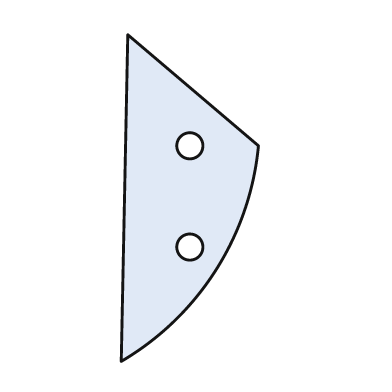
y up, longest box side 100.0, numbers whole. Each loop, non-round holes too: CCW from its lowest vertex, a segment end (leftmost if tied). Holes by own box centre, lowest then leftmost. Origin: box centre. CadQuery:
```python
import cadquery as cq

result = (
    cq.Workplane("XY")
    .moveTo(-21.0, -50.0)
    .threePointArc((8.0, -22.0), (21.0, 16.0))
    .lineTo(-19.0, 50.0)
    .close()
    .moveTo(0.0, -15.0)
    .circle(4.0)
    .moveTo(0.0, 16.0)
    .circle(4.0)
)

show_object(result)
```